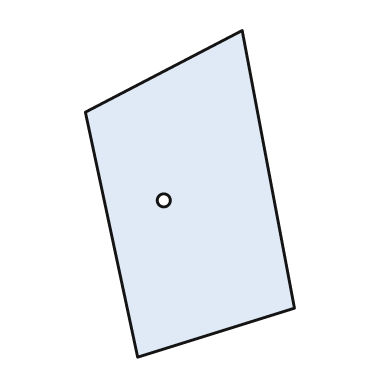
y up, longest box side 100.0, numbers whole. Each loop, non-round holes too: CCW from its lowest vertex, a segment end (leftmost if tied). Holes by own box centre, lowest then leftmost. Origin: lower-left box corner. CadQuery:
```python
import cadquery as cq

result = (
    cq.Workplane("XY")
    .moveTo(16.0, 0.0)
    .lineTo(64.0, 15.0)
    .lineTo(48.0, 100.0)
    .lineTo(0.0, 75.0)
    .close()
    .moveTo(24.0, 48.0)
    .circle(2.0)
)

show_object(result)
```